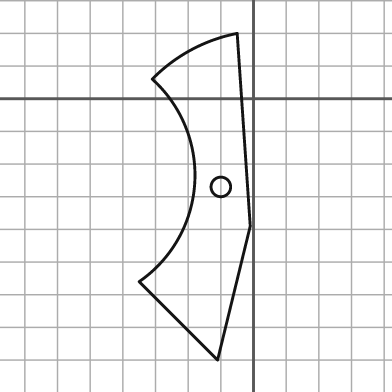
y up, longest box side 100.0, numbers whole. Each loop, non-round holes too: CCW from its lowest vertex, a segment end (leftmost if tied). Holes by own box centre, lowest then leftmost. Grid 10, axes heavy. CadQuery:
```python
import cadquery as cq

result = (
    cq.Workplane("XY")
    .moveTo(-11.0, -80.0)
    .lineTo(-1.0, -39.0)
    .lineTo(-5.0, 20.0)
    .threePointArc((-19.0, 15.0), (-31.0, 6.0))
    .threePointArc((-18.0, -26.0), (-35.0, -56.0))
    .close()
    .moveTo(-10.0, -27.0)
    .circle(3.0)
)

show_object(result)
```